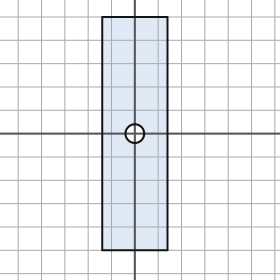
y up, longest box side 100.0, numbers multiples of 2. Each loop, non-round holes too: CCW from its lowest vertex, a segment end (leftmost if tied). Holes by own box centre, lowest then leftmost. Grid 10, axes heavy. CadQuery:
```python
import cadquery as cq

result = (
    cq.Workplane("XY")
    .moveTo(-14.0, -50.0)
    .lineTo(14.0, -50.0)
    .lineTo(14.0, 50.0)
    .lineTo(-14.0, 50.0)
    .close()
    .moveTo(0.0, 0.0)
    .circle(4.0)
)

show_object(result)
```